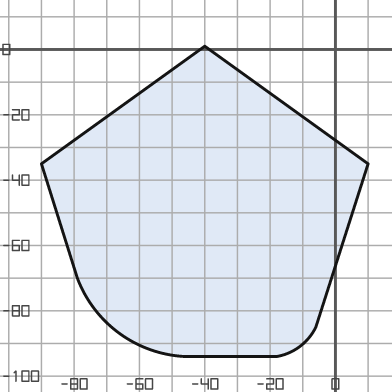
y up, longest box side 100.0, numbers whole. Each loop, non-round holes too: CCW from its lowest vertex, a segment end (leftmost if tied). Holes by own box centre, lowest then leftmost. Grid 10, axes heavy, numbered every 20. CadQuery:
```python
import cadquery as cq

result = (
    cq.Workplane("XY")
    .moveTo(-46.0, -94.0)
    .lineTo(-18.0, -94.0)
    .threePointArc((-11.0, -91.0), (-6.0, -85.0))
    .lineTo(10.0, -35.0)
    .lineTo(-40.0, 1.0)
    .lineTo(-90.0, -35.0)
    .lineTo(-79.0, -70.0)
    .threePointArc((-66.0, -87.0), (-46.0, -94.0))
    .close()
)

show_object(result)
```